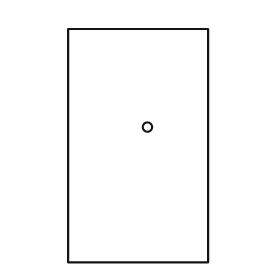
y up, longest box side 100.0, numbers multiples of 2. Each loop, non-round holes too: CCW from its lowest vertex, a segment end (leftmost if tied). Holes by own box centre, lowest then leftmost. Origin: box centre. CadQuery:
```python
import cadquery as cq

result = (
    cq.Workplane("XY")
    .moveTo(-30.0, -50.0)
    .lineTo(30.0, -50.0)
    .lineTo(30.0, 50.0)
    .lineTo(-30.0, 50.0)
    .close()
    .moveTo(4.0, 8.0)
    .circle(2.0)
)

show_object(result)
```